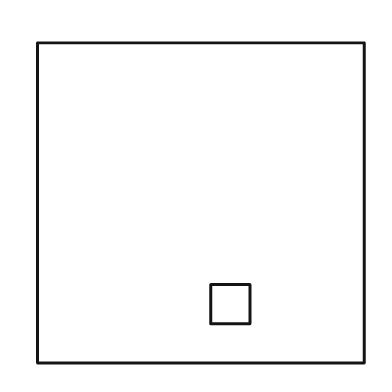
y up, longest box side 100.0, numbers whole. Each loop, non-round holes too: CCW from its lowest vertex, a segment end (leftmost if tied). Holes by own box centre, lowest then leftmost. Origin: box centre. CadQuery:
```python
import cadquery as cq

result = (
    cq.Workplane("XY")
    .moveTo(-50.0, -49.0)
    .lineTo(50.0, -49.0)
    .lineTo(50.0, 49.0)
    .lineTo(-50.0, 49.0)
    .close()
    .moveTo(3.0, -37.0)
    .lineTo(15.0, -37.0)
    .lineTo(15.0, -25.0)
    .lineTo(3.0, -25.0)
    .close()
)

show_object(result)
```